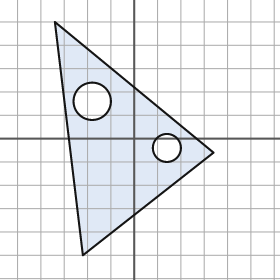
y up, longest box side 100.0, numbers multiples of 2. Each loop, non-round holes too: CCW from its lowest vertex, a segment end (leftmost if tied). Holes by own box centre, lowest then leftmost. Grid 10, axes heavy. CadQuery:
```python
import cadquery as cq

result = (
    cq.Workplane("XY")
    .moveTo(-22.0, -50.0)
    .lineTo(34.0, -6.0)
    .lineTo(-34.0, 50.0)
    .close()
    .moveTo(14.0, -4.0)
    .circle(6.0)
    .moveTo(-18.0, 16.0)
    .circle(8.0)
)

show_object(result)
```